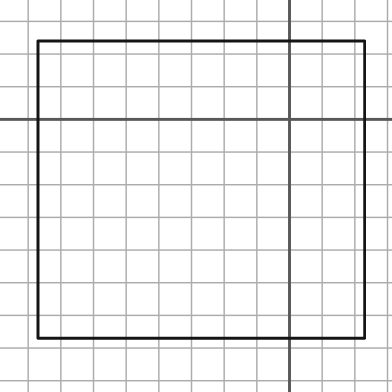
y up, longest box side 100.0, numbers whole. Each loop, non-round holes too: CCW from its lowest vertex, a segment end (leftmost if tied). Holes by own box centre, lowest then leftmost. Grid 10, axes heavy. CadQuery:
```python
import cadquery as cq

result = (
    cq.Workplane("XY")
    .moveTo(-77.0, -67.0)
    .lineTo(23.0, -67.0)
    .lineTo(23.0, 24.0)
    .lineTo(-77.0, 24.0)
    .close()
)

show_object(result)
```